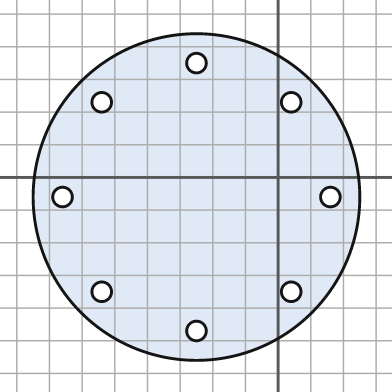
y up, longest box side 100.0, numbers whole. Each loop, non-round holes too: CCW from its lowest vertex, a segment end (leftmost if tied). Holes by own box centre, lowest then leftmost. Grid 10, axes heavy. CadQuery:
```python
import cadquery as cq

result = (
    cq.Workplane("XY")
    .moveTo(-25.0, -6.0)
    .circle(50.0)
    .moveTo(-25.0, -47.0)
    .circle(3.0)
    .moveTo(-54.0, -35.0)
    .circle(3.0)
    .moveTo(4.0, -35.0)
    .circle(3.0)
    .moveTo(-66.0, -6.0)
    .circle(3.0)
    .moveTo(16.0, -6.0)
    .circle(3.0)
    .moveTo(-54.0, 23.0)
    .circle(3.0)
    .moveTo(4.0, 23.0)
    .circle(3.0)
    .moveTo(-25.0, 35.0)
    .circle(3.0)
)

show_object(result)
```